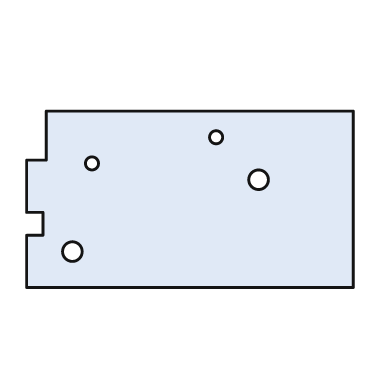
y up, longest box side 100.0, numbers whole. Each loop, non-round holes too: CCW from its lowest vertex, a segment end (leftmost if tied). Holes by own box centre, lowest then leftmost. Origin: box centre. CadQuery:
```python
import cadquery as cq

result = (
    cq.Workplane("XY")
    .moveTo(-50.0, -27.0)
    .lineTo(50.0, -27.0)
    .lineTo(50.0, 27.0)
    .lineTo(-44.0, 27.0)
    .lineTo(-44.0, 12.0)
    .lineTo(-50.0, 12.0)
    .lineTo(-50.0, -4.0)
    .lineTo(-45.0, -4.0)
    .lineTo(-45.0, -11.0)
    .lineTo(-50.0, -11.0)
    .close()
    .moveTo(-36.0, -16.0)
    .circle(3.0)
    .moveTo(21.0, 6.0)
    .circle(3.0)
    .moveTo(-30.0, 11.0)
    .circle(2.0)
    .moveTo(8.0, 19.0)
    .circle(2.0)
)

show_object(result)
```